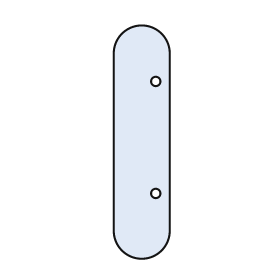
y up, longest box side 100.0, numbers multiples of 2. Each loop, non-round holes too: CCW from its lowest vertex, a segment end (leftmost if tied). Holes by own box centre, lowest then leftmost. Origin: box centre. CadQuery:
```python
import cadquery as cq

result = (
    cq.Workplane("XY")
    .moveTo(-12.0, -38.0)
    .threePointArc((0.0, -50.0), (12.0, -38.0))
    .lineTo(12.0, 38.0)
    .threePointArc((0.0, 50.0), (-12.0, 38.0))
    .close()
    .moveTo(6.0, -22.0)
    .circle(2.0)
    .moveTo(6.0, 26.0)
    .circle(2.0)
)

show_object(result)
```